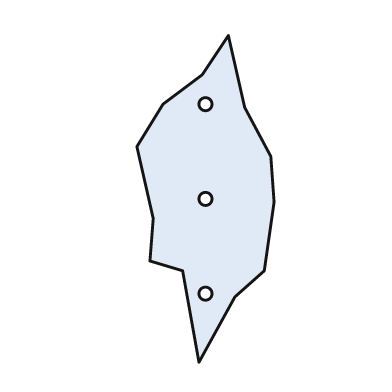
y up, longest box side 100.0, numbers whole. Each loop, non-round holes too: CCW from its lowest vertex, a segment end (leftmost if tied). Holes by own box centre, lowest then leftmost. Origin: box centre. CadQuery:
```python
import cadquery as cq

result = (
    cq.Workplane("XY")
    .moveTo(-2.0, -50.0)
    .lineTo(9.0, -30.0)
    .lineTo(18.0, -22.0)
    .lineTo(21.0, -1.0)
    .lineTo(20.0, 13.0)
    .lineTo(12.0, 28.0)
    .lineTo(7.0, 50.0)
    .lineTo(-1.0, 38.0)
    .lineTo(-13.0, 29.0)
    .lineTo(-21.0, 16.0)
    .lineTo(-16.0, -6.0)
    .lineTo(-17.0, -19.0)
    .lineTo(-7.0, -22.0)
    .close()
    .moveTo(0.0, -29.0)
    .circle(2.0)
    .moveTo(0.0, 0.0)
    .circle(2.0)
    .moveTo(0.0, 29.0)
    .circle(2.0)
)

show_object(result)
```